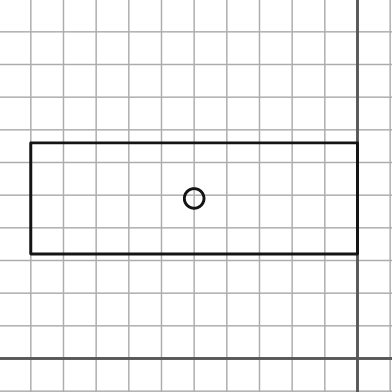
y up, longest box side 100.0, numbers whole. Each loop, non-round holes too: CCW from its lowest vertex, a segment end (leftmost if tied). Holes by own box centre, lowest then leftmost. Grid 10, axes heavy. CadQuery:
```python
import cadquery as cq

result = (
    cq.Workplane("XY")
    .moveTo(-100.0, 32.0)
    .lineTo(0.0, 32.0)
    .lineTo(0.0, 66.0)
    .lineTo(-100.0, 66.0)
    .close()
    .moveTo(-50.0, 49.0)
    .circle(3.0)
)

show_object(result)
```